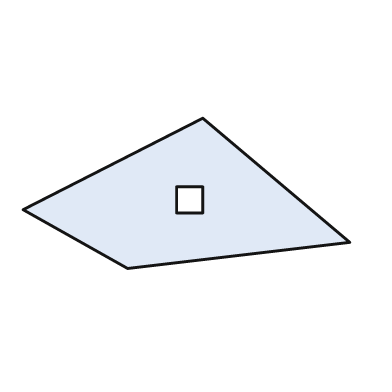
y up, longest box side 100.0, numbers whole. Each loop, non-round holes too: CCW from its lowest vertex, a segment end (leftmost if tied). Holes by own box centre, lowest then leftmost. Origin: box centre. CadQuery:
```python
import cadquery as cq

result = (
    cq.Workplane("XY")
    .moveTo(-18.0, -23.0)
    .lineTo(50.0, -15.0)
    .lineTo(5.0, 23.0)
    .lineTo(-50.0, -5.0)
    .close()
    .moveTo(-3.0, -6.0)
    .lineTo(5.0, -6.0)
    .lineTo(5.0, 2.0)
    .lineTo(-3.0, 2.0)
    .close()
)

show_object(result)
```